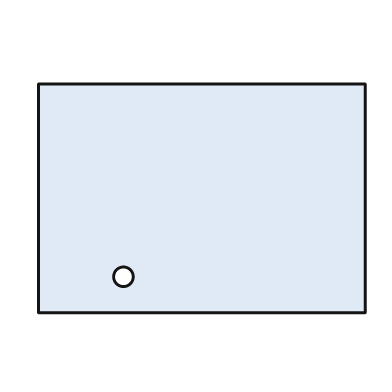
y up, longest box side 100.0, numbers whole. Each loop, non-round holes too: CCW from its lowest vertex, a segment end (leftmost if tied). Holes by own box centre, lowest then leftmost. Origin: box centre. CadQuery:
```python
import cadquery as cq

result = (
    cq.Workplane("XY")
    .moveTo(-50.0, -35.0)
    .lineTo(50.0, -35.0)
    .lineTo(50.0, 35.0)
    .lineTo(-50.0, 35.0)
    .close()
    .moveTo(-24.0, -24.0)
    .circle(3.0)
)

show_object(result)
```